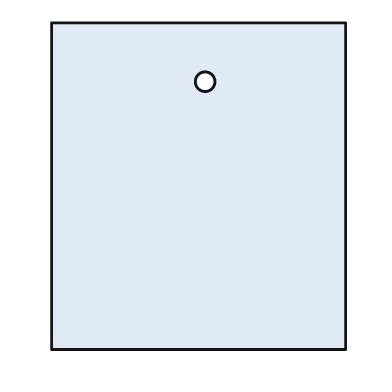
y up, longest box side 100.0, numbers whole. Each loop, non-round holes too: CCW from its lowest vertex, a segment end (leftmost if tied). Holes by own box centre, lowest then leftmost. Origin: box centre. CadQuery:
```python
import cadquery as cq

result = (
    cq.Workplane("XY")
    .moveTo(-45.0, -50.0)
    .lineTo(45.0, -50.0)
    .lineTo(45.0, 50.0)
    .lineTo(-45.0, 50.0)
    .close()
    .moveTo(2.0, 32.0)
    .circle(3.0)
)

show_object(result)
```